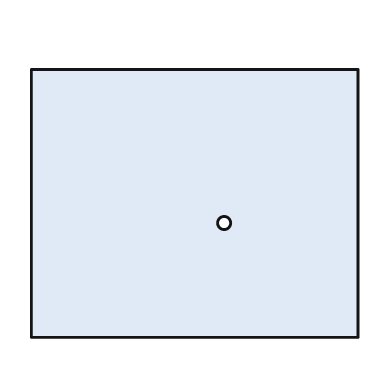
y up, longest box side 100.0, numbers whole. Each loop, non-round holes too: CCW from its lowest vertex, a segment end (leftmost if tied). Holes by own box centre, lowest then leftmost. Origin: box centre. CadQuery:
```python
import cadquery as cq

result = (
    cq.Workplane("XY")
    .moveTo(-50.0, -41.0)
    .lineTo(50.0, -41.0)
    .lineTo(50.0, 41.0)
    .lineTo(-50.0, 41.0)
    .close()
    .moveTo(9.0, -6.0)
    .circle(2.0)
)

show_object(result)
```